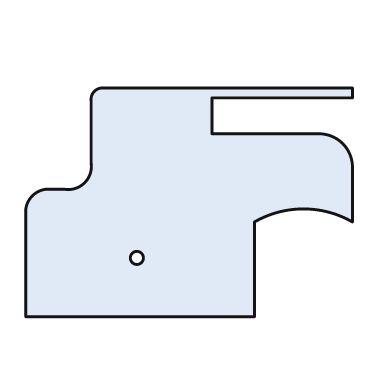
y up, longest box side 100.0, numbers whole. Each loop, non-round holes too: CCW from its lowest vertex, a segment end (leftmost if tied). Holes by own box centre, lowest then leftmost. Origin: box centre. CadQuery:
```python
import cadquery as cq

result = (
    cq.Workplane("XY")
    .moveTo(-50.0, -35.0)
    .lineTo(20.0, -35.0)
    .lineTo(20.0, -6.0)
    .threePointArc((35.0, -2.0), (50.0, -6.0))
    .lineTo(50.0, 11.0)
    .threePointArc((47.0, 18.0), (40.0, 21.0))
    .lineTo(7.0, 21.0)
    .lineTo(7.0, 32.0)
    .lineTo(50.0, 32.0)
    .lineTo(50.0, 35.0)
    .lineTo(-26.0, 35.0)
    .threePointArc((-29.0, 34.0), (-30.0, 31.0))
    .lineTo(-30.0, 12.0)
    .threePointArc((-32.0, 6.0), (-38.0, 4.0))
    .lineTo(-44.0, 4.0)
    .threePointArc((-48.0, 2.0), (-50.0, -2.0))
    .close()
    .moveTo(-16.0, -17.0)
    .circle(2.0)
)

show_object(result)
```